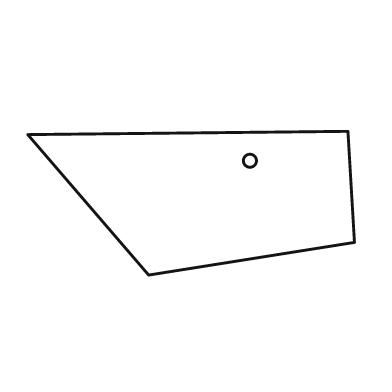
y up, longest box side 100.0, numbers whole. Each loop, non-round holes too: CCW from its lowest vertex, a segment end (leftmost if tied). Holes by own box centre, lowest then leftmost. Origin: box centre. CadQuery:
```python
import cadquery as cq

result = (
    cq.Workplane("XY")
    .moveTo(-13.0, -22.0)
    .lineTo(50.0, -12.0)
    .lineTo(48.0, 22.0)
    .lineTo(-50.0, 21.0)
    .close()
    .moveTo(18.0, 13.0)
    .circle(2.0)
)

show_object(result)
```